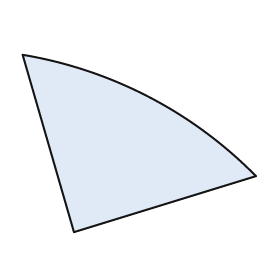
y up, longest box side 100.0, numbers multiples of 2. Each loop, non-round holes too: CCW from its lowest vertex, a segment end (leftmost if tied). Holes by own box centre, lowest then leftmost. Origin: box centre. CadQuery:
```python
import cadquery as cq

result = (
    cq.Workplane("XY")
    .moveTo(-28.0, -38.0)
    .lineTo(50.0, -14.0)
    .threePointArc((4.0, 20.0), (-50.0, 38.0))
    .close()
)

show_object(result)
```